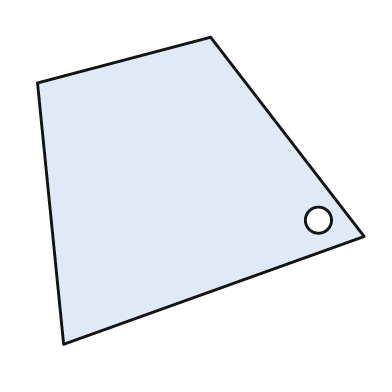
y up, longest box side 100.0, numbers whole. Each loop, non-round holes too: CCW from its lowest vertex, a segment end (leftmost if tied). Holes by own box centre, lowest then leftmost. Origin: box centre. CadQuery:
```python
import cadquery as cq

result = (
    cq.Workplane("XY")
    .moveTo(-42.0, -47.0)
    .lineTo(50.0, -14.0)
    .lineTo(3.0, 47.0)
    .lineTo(-50.0, 33.0)
    .close()
    .moveTo(36.0, -9.0)
    .circle(4.0)
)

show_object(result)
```